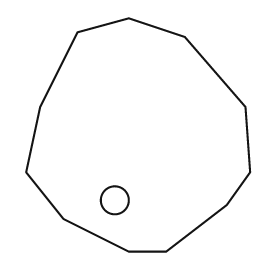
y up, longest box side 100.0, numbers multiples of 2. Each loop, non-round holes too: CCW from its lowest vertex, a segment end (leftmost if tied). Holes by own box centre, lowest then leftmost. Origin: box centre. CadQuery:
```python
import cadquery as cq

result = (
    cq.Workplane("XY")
    .moveTo(-4.0, -50.0)
    .lineTo(12.0, -50.0)
    .lineTo(38.0, -30.0)
    .lineTo(48.0, -16.0)
    .lineTo(46.0, 12.0)
    .lineTo(20.0, 42.0)
    .lineTo(-4.0, 50.0)
    .lineTo(-26.0, 44.0)
    .lineTo(-42.0, 12.0)
    .lineTo(-48.0, -16.0)
    .lineTo(-32.0, -36.0)
    .close()
    .moveTo(-10.0, -28.0)
    .circle(6.0)
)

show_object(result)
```